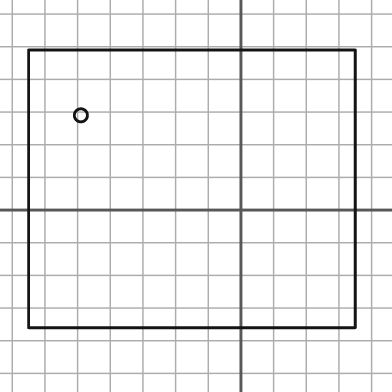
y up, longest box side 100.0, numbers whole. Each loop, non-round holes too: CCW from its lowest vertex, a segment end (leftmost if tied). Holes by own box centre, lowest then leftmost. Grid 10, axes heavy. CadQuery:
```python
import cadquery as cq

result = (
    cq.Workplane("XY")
    .moveTo(-65.0, -36.0)
    .lineTo(35.0, -36.0)
    .lineTo(35.0, 49.0)
    .lineTo(-65.0, 49.0)
    .close()
    .moveTo(-49.0, 29.0)
    .circle(2.0)
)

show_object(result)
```